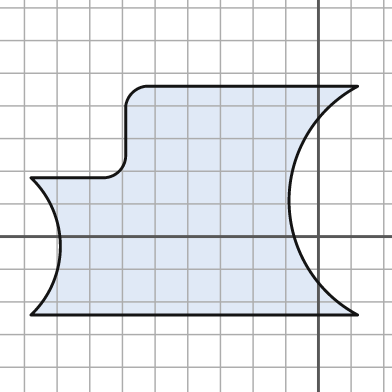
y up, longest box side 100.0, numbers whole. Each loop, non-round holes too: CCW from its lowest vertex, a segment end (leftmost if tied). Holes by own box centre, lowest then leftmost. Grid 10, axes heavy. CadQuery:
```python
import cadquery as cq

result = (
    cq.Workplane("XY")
    .moveTo(-88.0, -24.0)
    .lineTo(12.0, -24.0)
    .threePointArc((-9.0, 11.0), (12.0, 46.0))
    .lineTo(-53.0, 46.0)
    .threePointArc((-57.0, 44.0), (-59.0, 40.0))
    .lineTo(-59.0, 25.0)
    .threePointArc((-61.0, 20.0), (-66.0, 18.0))
    .lineTo(-88.0, 18.0)
    .threePointArc((-79.0, -3.0), (-88.0, -24.0))
    .close()
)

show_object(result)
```